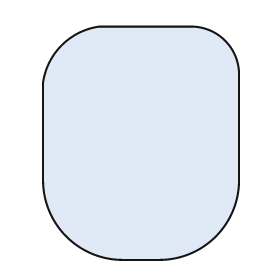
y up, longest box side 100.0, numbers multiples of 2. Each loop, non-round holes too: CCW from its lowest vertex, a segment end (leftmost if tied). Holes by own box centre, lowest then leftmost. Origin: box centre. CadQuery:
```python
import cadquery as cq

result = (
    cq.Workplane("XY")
    .moveTo(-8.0, -50.0)
    .lineTo(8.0, -50.0)
    .threePointArc((32.0, -40.0), (42.0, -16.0))
    .lineTo(42.0, 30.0)
    .threePointArc((36.0, 44.0), (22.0, 50.0))
    .lineTo(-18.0, 50.0)
    .threePointArc((-34.0, 42.0), (-42.0, 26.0))
    .lineTo(-42.0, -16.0)
    .threePointArc((-32.0, -40.0), (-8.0, -50.0))
    .close()
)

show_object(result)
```